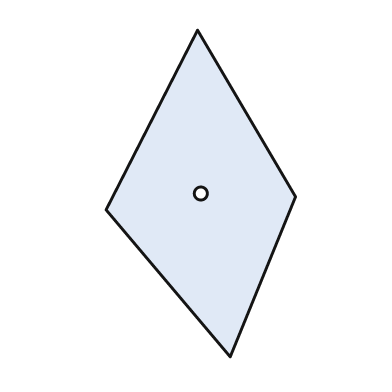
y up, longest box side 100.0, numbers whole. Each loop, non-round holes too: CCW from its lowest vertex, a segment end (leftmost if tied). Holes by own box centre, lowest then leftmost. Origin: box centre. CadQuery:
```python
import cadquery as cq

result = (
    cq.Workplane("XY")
    .moveTo(9.0, -50.0)
    .lineTo(29.0, -1.0)
    .lineTo(-1.0, 50.0)
    .lineTo(-29.0, -5.0)
    .close()
    .moveTo(0.0, 0.0)
    .circle(2.0)
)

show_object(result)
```